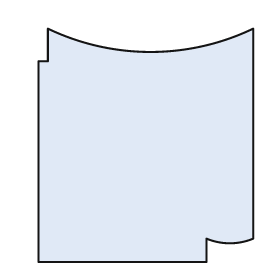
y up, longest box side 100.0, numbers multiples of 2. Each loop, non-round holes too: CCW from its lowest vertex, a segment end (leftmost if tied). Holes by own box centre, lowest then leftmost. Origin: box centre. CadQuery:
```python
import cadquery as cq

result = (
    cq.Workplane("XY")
    .moveTo(-46.0, -50.0)
    .lineTo(26.0, -50.0)
    .lineTo(26.0, -40.0)
    .threePointArc((36.0, -42.0), (46.0, -40.0))
    .lineTo(46.0, 50.0)
    .threePointArc((2.0, 40.0), (-42.0, 50.0))
    .lineTo(-42.0, 36.0)
    .lineTo(-46.0, 36.0)
    .close()
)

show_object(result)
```